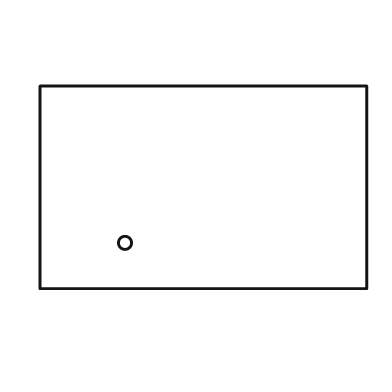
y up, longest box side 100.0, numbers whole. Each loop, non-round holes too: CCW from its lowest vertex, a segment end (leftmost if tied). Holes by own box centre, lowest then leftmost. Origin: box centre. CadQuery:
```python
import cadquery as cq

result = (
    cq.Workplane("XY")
    .moveTo(-50.0, -31.0)
    .lineTo(50.0, -31.0)
    .lineTo(50.0, 31.0)
    .lineTo(-50.0, 31.0)
    .close()
    .moveTo(-24.0, -17.0)
    .circle(2.0)
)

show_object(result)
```